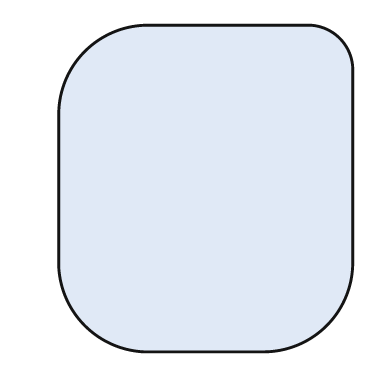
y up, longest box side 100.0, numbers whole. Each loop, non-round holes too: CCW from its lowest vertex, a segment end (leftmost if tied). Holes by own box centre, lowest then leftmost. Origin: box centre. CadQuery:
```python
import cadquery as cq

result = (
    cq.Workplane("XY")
    .moveTo(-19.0, -50.0)
    .lineTo(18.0, -50.0)
    .threePointArc((37.0, -42.0), (45.0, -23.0))
    .lineTo(45.0, 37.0)
    .threePointArc((41.0, 46.0), (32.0, 50.0))
    .lineTo(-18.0, 50.0)
    .threePointArc((-37.0, 42.0), (-45.0, 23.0))
    .lineTo(-45.0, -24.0)
    .threePointArc((-37.0, -42.0), (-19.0, -50.0))
    .close()
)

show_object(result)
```